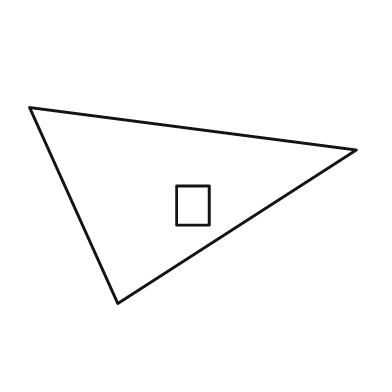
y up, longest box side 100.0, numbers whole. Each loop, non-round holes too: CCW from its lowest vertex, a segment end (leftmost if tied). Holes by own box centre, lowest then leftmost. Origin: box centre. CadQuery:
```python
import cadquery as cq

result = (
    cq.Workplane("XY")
    .moveTo(-23.0, -30.0)
    .lineTo(50.0, 17.0)
    .lineTo(-50.0, 30.0)
    .close()
    .moveTo(-5.0, -6.0)
    .lineTo(5.0, -6.0)
    .lineTo(5.0, 6.0)
    .lineTo(-5.0, 6.0)
    .close()
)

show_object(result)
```